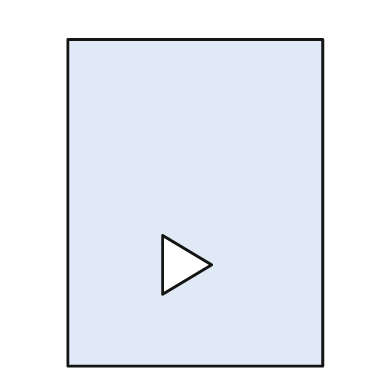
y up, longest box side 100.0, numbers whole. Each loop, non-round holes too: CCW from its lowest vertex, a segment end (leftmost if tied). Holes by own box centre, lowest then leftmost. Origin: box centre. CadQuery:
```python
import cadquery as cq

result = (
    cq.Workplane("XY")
    .moveTo(-39.0, -50.0)
    .lineTo(39.0, -50.0)
    .lineTo(39.0, 50.0)
    .lineTo(-39.0, 50.0)
    .close()
    .moveTo(-10.0, -28.0)
    .lineTo(5.0, -19.0)
    .lineTo(-10.0, -10.0)
    .close()
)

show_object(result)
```